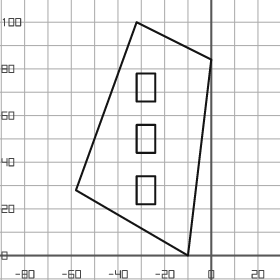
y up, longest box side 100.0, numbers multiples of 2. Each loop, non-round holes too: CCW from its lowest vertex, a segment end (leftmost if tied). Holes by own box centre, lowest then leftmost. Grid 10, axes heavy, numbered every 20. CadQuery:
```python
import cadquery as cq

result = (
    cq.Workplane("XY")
    .moveTo(-10.0, 0.0)
    .lineTo(0.0, 84.0)
    .lineTo(-32.0, 100.0)
    .lineTo(-58.0, 28.0)
    .close()
    .moveTo(-32.0, 22.0)
    .lineTo(-24.0, 22.0)
    .lineTo(-24.0, 34.0)
    .lineTo(-32.0, 34.0)
    .close()
    .moveTo(-32.0, 44.0)
    .lineTo(-24.0, 44.0)
    .lineTo(-24.0, 56.0)
    .lineTo(-32.0, 56.0)
    .close()
    .moveTo(-32.0, 66.0)
    .lineTo(-24.0, 66.0)
    .lineTo(-24.0, 78.0)
    .lineTo(-32.0, 78.0)
    .close()
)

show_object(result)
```